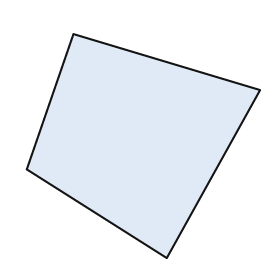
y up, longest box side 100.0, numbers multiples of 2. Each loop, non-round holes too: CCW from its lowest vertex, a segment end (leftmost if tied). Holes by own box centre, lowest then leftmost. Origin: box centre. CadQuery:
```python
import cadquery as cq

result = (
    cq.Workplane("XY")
    .moveTo(10.0, -48.0)
    .lineTo(50.0, 24.0)
    .lineTo(-30.0, 48.0)
    .lineTo(-50.0, -10.0)
    .close()
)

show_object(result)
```